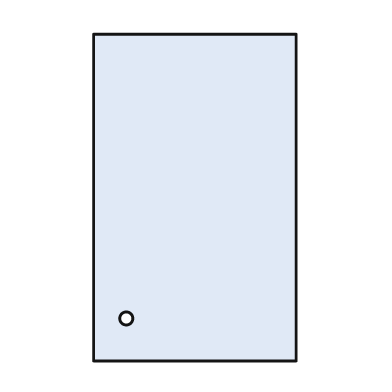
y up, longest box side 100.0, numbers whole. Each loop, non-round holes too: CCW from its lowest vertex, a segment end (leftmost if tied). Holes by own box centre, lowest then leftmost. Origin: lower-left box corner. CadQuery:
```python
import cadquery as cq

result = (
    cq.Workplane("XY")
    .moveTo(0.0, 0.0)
    .lineTo(62.0, 0.0)
    .lineTo(62.0, 100.0)
    .lineTo(0.0, 100.0)
    .close()
    .moveTo(10.0, 13.0)
    .circle(2.0)
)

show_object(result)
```